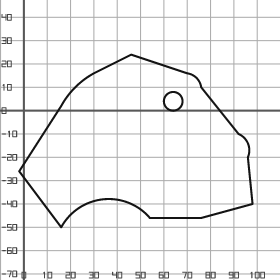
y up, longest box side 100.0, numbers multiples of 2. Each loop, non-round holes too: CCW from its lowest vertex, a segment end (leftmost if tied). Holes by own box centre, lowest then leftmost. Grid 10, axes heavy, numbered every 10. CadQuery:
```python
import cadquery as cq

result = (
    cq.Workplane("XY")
    .moveTo(16.0, -50.0)
    .threePointArc((34.0, -38.0), (54.0, -46.0))
    .lineTo(76.0, -46.0)
    .lineTo(98.0, -40.0)
    .lineTo(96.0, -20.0)
    .threePointArc((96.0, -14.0), (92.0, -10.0))
    .lineTo(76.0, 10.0)
    .threePointArc((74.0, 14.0), (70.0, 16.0))
    .lineTo(46.0, 24.0)
    .lineTo(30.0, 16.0)
    .threePointArc((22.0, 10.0), (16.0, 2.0))
    .lineTo(-2.0, -26.0)
    .close()
    .moveTo(64.0, 4.0)
    .circle(4.0)
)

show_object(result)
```